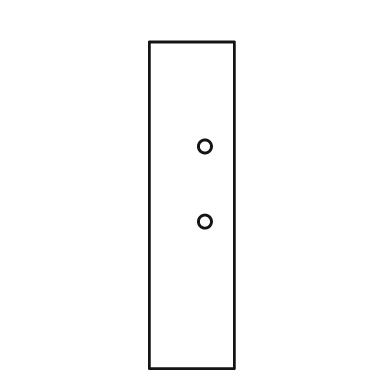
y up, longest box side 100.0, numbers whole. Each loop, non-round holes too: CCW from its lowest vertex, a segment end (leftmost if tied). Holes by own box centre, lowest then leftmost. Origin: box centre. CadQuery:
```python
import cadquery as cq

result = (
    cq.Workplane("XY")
    .moveTo(-13.0, -50.0)
    .lineTo(13.0, -50.0)
    .lineTo(13.0, 50.0)
    .lineTo(-13.0, 50.0)
    .close()
    .moveTo(4.0, -5.0)
    .circle(2.0)
    .moveTo(4.0, 18.0)
    .circle(2.0)
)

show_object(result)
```